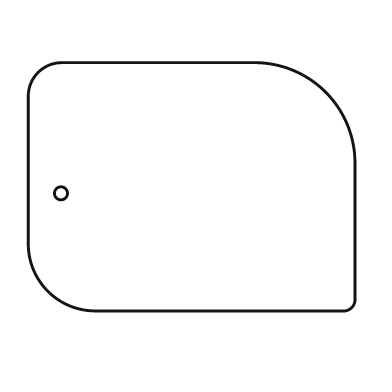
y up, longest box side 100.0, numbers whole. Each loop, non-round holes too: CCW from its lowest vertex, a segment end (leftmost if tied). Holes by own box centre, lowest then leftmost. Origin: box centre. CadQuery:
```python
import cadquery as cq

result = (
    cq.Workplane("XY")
    .moveTo(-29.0, -38.0)
    .lineTo(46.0, -38.0)
    .threePointArc((49.0, -37.0), (50.0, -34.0))
    .lineTo(50.0, 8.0)
    .threePointArc((41.0, 29.0), (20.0, 38.0))
    .lineTo(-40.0, 38.0)
    .threePointArc((-47.0, 35.0), (-50.0, 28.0))
    .lineTo(-50.0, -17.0)
    .threePointArc((-44.0, -32.0), (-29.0, -38.0))
    .close()
    .moveTo(-40.0, -2.0)
    .circle(2.0)
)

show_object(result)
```